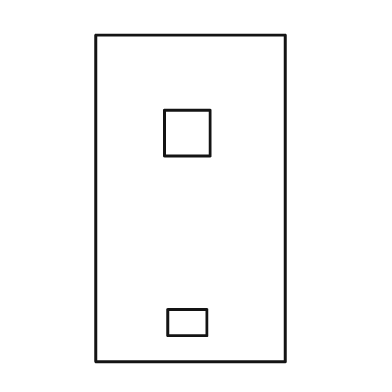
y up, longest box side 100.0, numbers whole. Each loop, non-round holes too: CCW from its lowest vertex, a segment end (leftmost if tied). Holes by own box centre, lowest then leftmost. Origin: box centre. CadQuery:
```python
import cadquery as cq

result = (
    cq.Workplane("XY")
    .moveTo(-29.0, -50.0)
    .lineTo(29.0, -50.0)
    .lineTo(29.0, 50.0)
    .lineTo(-29.0, 50.0)
    .close()
    .moveTo(-7.0, -42.0)
    .lineTo(5.0, -42.0)
    .lineTo(5.0, -34.0)
    .lineTo(-7.0, -34.0)
    .close()
    .moveTo(-8.0, 13.0)
    .lineTo(6.0, 13.0)
    .lineTo(6.0, 27.0)
    .lineTo(-8.0, 27.0)
    .close()
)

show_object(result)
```